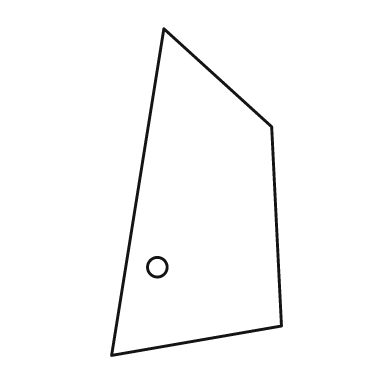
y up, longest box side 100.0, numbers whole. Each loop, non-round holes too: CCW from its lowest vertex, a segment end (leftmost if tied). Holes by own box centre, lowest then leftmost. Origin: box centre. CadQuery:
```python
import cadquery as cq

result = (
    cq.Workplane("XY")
    .moveTo(-26.0, -50.0)
    .lineTo(26.0, -41.0)
    .lineTo(23.0, 20.0)
    .lineTo(-10.0, 50.0)
    .close()
    .moveTo(-12.0, -23.0)
    .circle(3.0)
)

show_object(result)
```